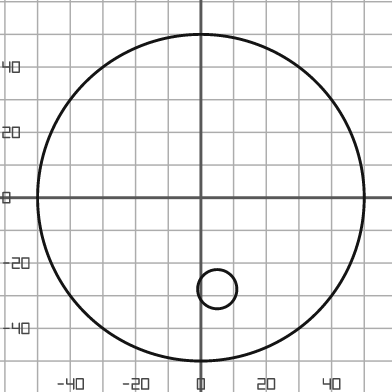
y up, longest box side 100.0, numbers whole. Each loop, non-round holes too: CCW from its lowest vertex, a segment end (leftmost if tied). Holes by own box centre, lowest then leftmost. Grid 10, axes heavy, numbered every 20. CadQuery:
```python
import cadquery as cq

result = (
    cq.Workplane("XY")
    .moveTo(0.0, 0.0)
    .circle(50.0)
    .moveTo(5.0, -28.0)
    .circle(6.0)
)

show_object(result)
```